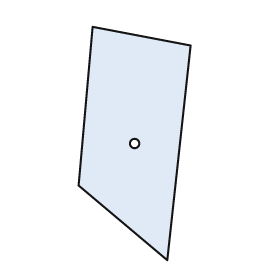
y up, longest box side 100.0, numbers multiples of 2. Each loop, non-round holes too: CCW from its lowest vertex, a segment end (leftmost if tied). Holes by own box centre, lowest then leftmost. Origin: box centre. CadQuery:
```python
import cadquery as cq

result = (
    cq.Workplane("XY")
    .moveTo(14.0, -50.0)
    .lineTo(24.0, 42.0)
    .lineTo(-18.0, 50.0)
    .lineTo(-24.0, -18.0)
    .close()
    .moveTo(0.0, 0.0)
    .circle(2.0)
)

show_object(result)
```